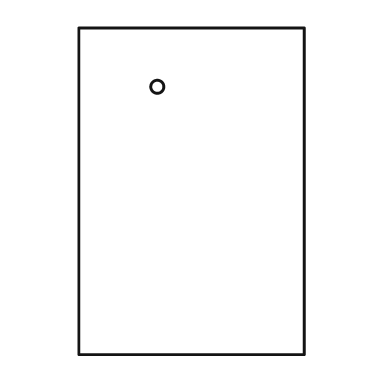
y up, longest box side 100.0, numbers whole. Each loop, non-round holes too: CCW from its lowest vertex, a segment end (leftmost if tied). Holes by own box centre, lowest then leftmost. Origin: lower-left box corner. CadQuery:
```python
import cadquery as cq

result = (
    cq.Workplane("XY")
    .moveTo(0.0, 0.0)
    .lineTo(69.0, 0.0)
    .lineTo(69.0, 100.0)
    .lineTo(0.0, 100.0)
    .close()
    .moveTo(24.0, 82.0)
    .circle(2.0)
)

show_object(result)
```